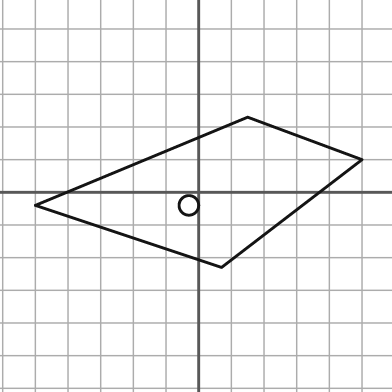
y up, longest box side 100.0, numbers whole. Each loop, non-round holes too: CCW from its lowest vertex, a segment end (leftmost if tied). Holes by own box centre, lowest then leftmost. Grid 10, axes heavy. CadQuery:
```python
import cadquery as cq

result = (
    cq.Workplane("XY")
    .moveTo(7.0, -23.0)
    .lineTo(50.0, 10.0)
    .lineTo(15.0, 23.0)
    .lineTo(-50.0, -4.0)
    .close()
    .moveTo(-3.0, -4.0)
    .circle(3.0)
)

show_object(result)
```